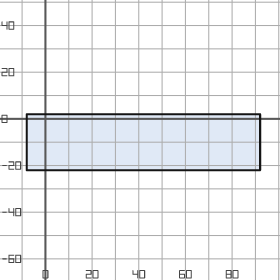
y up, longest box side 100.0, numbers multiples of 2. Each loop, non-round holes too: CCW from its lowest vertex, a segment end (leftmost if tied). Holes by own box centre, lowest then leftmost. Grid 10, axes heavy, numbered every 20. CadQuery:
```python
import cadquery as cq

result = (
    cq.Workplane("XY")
    .moveTo(-8.0, -22.0)
    .lineTo(92.0, -22.0)
    .lineTo(92.0, 2.0)
    .lineTo(-8.0, 2.0)
    .close()
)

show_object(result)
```